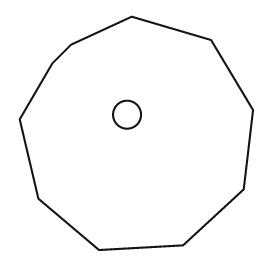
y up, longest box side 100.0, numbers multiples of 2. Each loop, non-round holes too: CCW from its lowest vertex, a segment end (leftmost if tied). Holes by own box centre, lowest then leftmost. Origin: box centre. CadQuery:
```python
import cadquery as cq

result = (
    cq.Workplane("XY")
    .moveTo(-16.0, -50.0)
    .lineTo(20.0, -48.0)
    .lineTo(46.0, -24.0)
    .lineTo(50.0, 10.0)
    .lineTo(32.0, 40.0)
    .lineTo(-2.0, 50.0)
    .lineTo(-28.0, 38.0)
    .lineTo(-36.0, 30.0)
    .lineTo(-50.0, 6.0)
    .lineTo(-42.0, -28.0)
    .close()
    .moveTo(-4.0, 8.0)
    .circle(6.0)
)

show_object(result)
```